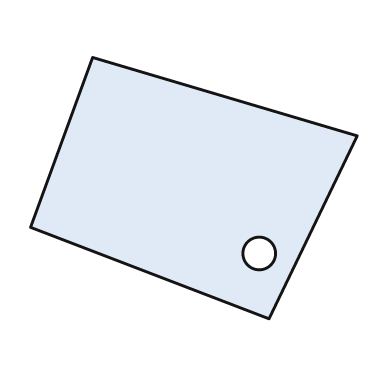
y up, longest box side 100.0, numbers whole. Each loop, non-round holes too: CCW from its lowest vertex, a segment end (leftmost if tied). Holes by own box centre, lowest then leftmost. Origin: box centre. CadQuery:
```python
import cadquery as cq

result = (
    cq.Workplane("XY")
    .moveTo(23.0, -40.0)
    .lineTo(50.0, 16.0)
    .lineTo(-31.0, 40.0)
    .lineTo(-50.0, -12.0)
    .close()
    .moveTo(20.0, -20.0)
    .circle(5.0)
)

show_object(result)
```